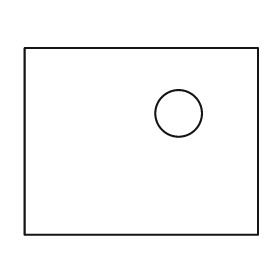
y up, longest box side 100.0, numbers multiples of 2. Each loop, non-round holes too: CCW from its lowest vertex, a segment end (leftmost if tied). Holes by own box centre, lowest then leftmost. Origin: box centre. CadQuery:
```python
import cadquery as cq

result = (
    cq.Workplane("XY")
    .moveTo(-50.0, -40.0)
    .lineTo(50.0, -40.0)
    .lineTo(50.0, 40.0)
    .lineTo(-50.0, 40.0)
    .close()
    .moveTo(16.0, 12.0)
    .circle(10.0)
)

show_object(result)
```